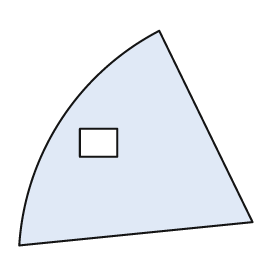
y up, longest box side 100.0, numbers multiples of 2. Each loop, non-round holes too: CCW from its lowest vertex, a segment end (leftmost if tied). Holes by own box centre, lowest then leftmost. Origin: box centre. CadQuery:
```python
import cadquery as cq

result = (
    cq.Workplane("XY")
    .moveTo(-50.0, -46.0)
    .lineTo(50.0, -36.0)
    .lineTo(10.0, 46.0)
    .threePointArc((-32.0, 8.0), (-50.0, -46.0))
    .close()
    .moveTo(-24.0, -8.0)
    .lineTo(-8.0, -8.0)
    .lineTo(-8.0, 4.0)
    .lineTo(-24.0, 4.0)
    .close()
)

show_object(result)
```